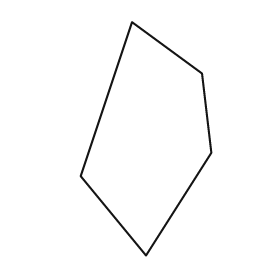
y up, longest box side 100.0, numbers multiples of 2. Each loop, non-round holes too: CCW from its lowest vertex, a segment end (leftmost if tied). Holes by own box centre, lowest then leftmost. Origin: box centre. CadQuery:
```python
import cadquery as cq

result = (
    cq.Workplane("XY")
    .moveTo(0.0, -50.0)
    .lineTo(28.0, -6.0)
    .lineTo(24.0, 28.0)
    .lineTo(-6.0, 50.0)
    .lineTo(-28.0, -16.0)
    .close()
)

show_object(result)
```